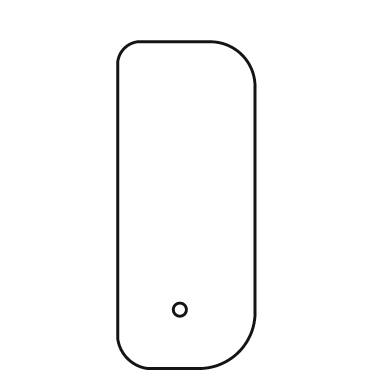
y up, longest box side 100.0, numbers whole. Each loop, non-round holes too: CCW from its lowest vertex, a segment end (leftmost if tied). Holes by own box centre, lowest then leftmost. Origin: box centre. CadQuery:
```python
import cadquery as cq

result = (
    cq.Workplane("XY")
    .moveTo(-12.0, -50.0)
    .lineTo(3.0, -50.0)
    .threePointArc((16.0, -45.0), (21.0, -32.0))
    .lineTo(21.0, 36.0)
    .threePointArc((17.0, 46.0), (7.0, 50.0))
    .lineTo(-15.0, 50.0)
    .threePointArc((-19.0, 48.0), (-21.0, 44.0))
    .lineTo(-21.0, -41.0)
    .threePointArc((-18.0, -47.0), (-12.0, -50.0))
    .close()
    .moveTo(-2.0, -32.0)
    .circle(2.0)
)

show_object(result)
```